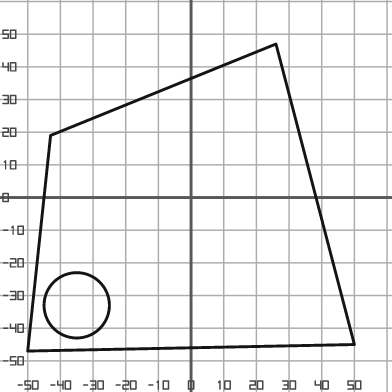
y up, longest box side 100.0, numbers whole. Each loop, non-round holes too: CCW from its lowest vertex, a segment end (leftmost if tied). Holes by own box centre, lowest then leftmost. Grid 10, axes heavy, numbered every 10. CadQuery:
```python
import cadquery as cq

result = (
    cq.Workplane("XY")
    .moveTo(-50.0, -47.0)
    .lineTo(50.0, -45.0)
    .lineTo(26.0, 47.0)
    .lineTo(-43.0, 19.0)
    .close()
    .moveTo(-35.0, -33.0)
    .circle(10.0)
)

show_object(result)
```